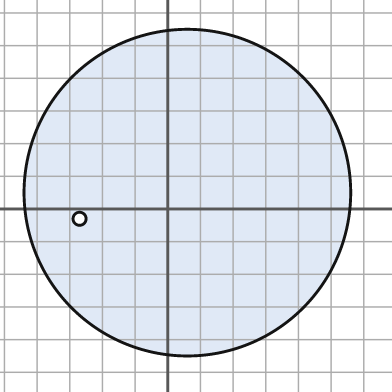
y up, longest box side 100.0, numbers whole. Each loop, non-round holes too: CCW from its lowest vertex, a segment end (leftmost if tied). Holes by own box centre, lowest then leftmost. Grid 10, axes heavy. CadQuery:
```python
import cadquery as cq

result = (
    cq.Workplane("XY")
    .moveTo(6.0, 5.0)
    .circle(50.0)
    .moveTo(-27.0, -3.0)
    .circle(2.0)
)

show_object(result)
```